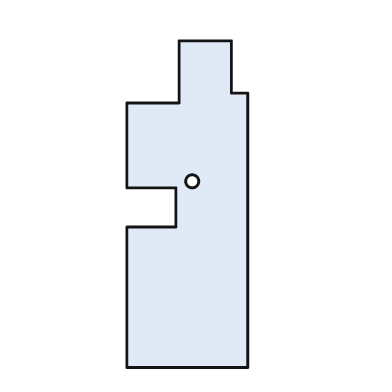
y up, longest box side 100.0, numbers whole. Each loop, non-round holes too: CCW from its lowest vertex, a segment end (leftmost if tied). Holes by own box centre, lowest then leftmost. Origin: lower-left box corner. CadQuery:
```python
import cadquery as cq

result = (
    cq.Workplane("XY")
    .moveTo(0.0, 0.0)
    .lineTo(37.0, 0.0)
    .lineTo(37.0, 84.0)
    .lineTo(32.0, 84.0)
    .lineTo(32.0, 100.0)
    .lineTo(16.0, 100.0)
    .lineTo(16.0, 81.0)
    .lineTo(0.0, 81.0)
    .lineTo(0.0, 55.0)
    .lineTo(15.0, 55.0)
    .lineTo(15.0, 43.0)
    .lineTo(0.0, 43.0)
    .close()
    .moveTo(20.0, 57.0)
    .circle(2.0)
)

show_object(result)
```